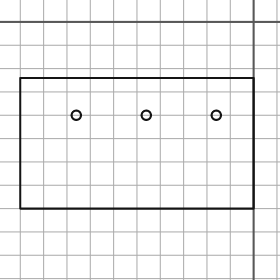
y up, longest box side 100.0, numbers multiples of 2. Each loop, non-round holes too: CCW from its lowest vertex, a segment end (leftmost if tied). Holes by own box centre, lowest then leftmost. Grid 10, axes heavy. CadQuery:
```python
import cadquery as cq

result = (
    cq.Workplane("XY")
    .moveTo(-100.0, -80.0)
    .lineTo(0.0, -80.0)
    .lineTo(0.0, -24.0)
    .lineTo(-100.0, -24.0)
    .close()
    .moveTo(-76.0, -40.0)
    .circle(2.0)
    .moveTo(-46.0, -40.0)
    .circle(2.0)
    .moveTo(-16.0, -40.0)
    .circle(2.0)
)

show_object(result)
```